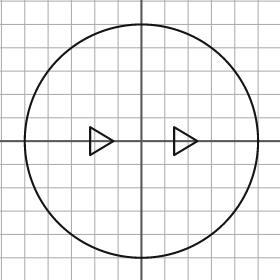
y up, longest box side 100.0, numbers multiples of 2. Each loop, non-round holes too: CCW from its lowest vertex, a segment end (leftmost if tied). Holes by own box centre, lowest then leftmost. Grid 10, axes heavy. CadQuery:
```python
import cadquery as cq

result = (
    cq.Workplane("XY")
    .moveTo(0.0, 0.0)
    .circle(50.0)
    .moveTo(-22.0, -6.0)
    .lineTo(-12.0, 0.0)
    .lineTo(-22.0, 6.0)
    .close()
    .moveTo(14.0, -6.0)
    .lineTo(24.0, 0.0)
    .lineTo(14.0, 6.0)
    .close()
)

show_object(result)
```